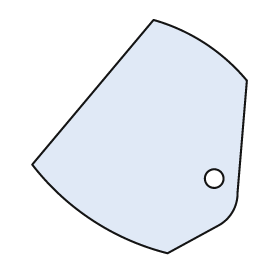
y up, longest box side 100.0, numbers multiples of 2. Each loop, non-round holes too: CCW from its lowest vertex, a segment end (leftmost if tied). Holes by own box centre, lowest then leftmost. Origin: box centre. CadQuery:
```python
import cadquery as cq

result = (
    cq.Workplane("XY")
    .moveTo(12.0, -50.0)
    .lineTo(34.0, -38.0)
    .threePointArc((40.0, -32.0), (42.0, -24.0))
    .lineTo(46.0, 24.0)
    .threePointArc((28.0, 40.0), (6.0, 50.0))
    .lineTo(-46.0, -12.0)
    .threePointArc((-20.0, -36.0), (12.0, -50.0))
    .close()
    .moveTo(32.0, -18.0)
    .circle(4.0)
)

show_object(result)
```